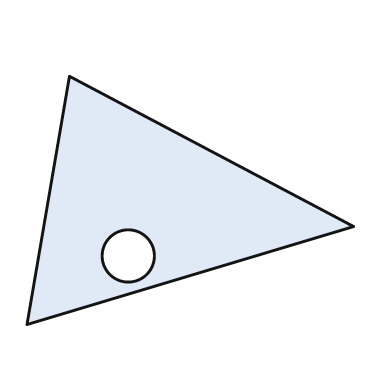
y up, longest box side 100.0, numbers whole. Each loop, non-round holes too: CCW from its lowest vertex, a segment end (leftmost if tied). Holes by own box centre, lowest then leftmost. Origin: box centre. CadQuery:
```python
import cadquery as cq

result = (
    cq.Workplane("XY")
    .moveTo(-50.0, -38.0)
    .lineTo(50.0, -8.0)
    .lineTo(-37.0, 38.0)
    .close()
    .moveTo(-19.0, -17.0)
    .circle(8.0)
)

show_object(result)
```